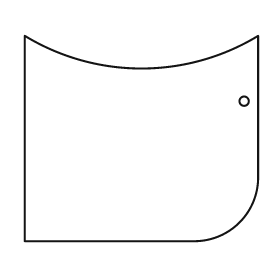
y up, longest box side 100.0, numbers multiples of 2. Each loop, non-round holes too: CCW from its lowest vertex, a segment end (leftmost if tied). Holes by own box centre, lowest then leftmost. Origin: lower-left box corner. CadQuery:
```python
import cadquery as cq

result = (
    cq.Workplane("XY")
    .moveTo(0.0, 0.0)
    .lineTo(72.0, 0.0)
    .threePointArc((92.0, 8.0), (100.0, 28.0))
    .lineTo(100.0, 88.0)
    .threePointArc((50.0, 74.0), (0.0, 88.0))
    .close()
    .moveTo(94.0, 60.0)
    .circle(2.0)
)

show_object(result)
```